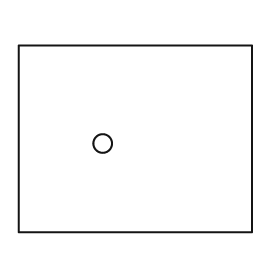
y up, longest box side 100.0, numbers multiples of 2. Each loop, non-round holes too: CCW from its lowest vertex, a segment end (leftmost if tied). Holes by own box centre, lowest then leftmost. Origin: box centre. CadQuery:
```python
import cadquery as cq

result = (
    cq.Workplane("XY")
    .moveTo(-50.0, -40.0)
    .lineTo(50.0, -40.0)
    .lineTo(50.0, 40.0)
    .lineTo(-50.0, 40.0)
    .close()
    .moveTo(-14.0, -2.0)
    .circle(4.0)
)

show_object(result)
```